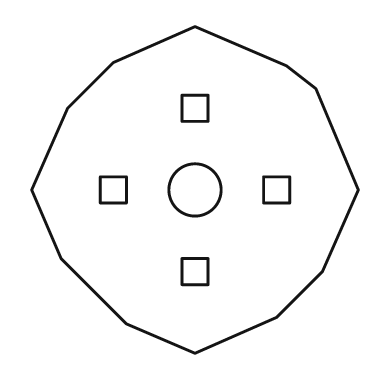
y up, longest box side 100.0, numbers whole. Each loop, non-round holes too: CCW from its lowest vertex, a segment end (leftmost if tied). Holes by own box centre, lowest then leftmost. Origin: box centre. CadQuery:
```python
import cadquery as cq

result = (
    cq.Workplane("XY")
    .moveTo(0.0, -50.0)
    .lineTo(25.0, -39.0)
    .lineTo(39.0, -25.0)
    .lineTo(50.0, 0.0)
    .lineTo(37.0, 31.0)
    .lineTo(28.0, 38.0)
    .lineTo(0.0, 50.0)
    .lineTo(-25.0, 39.0)
    .lineTo(-39.0, 25.0)
    .lineTo(-50.0, 0.0)
    .lineTo(-41.0, -21.0)
    .lineTo(-21.0, -41.0)
    .close()
    .moveTo(-4.0, -29.0)
    .lineTo(4.0, -29.0)
    .lineTo(4.0, -21.0)
    .lineTo(-4.0, -21.0)
    .close()
    .moveTo(-29.0, -4.0)
    .lineTo(-21.0, -4.0)
    .lineTo(-21.0, 4.0)
    .lineTo(-29.0, 4.0)
    .close()
    .moveTo(0.0, 0.0)
    .circle(8.0)
    .moveTo(21.0, -4.0)
    .lineTo(29.0, -4.0)
    .lineTo(29.0, 4.0)
    .lineTo(21.0, 4.0)
    .close()
    .moveTo(-4.0, 21.0)
    .lineTo(4.0, 21.0)
    .lineTo(4.0, 29.0)
    .lineTo(-4.0, 29.0)
    .close()
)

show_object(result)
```